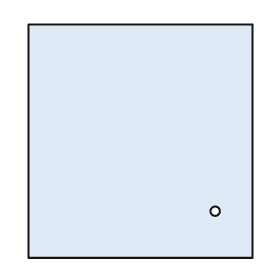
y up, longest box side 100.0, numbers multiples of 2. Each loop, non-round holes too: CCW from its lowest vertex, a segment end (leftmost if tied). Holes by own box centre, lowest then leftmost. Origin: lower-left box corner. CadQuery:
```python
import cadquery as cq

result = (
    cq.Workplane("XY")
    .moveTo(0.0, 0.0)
    .lineTo(96.0, 0.0)
    .lineTo(96.0, 100.0)
    .lineTo(0.0, 100.0)
    .close()
    .moveTo(80.0, 20.0)
    .circle(2.0)
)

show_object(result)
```